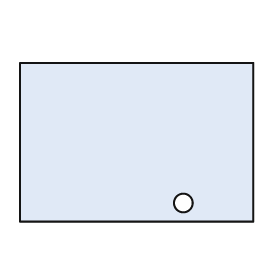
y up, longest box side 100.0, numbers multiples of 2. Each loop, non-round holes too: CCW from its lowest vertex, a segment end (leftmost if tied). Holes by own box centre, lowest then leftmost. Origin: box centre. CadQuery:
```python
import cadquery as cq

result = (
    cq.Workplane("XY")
    .moveTo(-50.0, -34.0)
    .lineTo(50.0, -34.0)
    .lineTo(50.0, 34.0)
    .lineTo(-50.0, 34.0)
    .close()
    .moveTo(20.0, -26.0)
    .circle(4.0)
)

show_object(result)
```